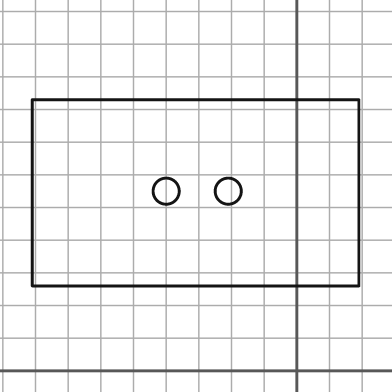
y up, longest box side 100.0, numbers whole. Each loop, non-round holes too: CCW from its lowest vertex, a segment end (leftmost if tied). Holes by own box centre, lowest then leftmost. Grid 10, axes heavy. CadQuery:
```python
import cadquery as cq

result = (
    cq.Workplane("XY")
    .moveTo(-81.0, 26.0)
    .lineTo(19.0, 26.0)
    .lineTo(19.0, 83.0)
    .lineTo(-81.0, 83.0)
    .close()
    .moveTo(-40.0, 55.0)
    .circle(4.0)
    .moveTo(-21.0, 55.0)
    .circle(4.0)
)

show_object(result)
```